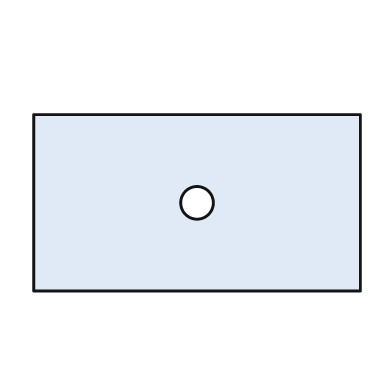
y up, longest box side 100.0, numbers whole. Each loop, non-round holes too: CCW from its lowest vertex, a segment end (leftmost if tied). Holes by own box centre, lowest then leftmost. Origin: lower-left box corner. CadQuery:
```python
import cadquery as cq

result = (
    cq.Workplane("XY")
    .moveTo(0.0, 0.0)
    .lineTo(100.0, 0.0)
    .lineTo(100.0, 54.0)
    .lineTo(0.0, 54.0)
    .close()
    .moveTo(50.0, 27.0)
    .circle(5.0)
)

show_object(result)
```